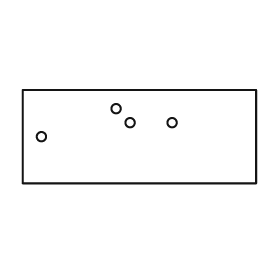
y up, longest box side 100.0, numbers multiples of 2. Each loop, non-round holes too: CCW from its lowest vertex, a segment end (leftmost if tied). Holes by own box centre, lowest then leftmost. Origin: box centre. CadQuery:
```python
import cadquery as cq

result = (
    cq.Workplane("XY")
    .moveTo(-50.0, -20.0)
    .lineTo(50.0, -20.0)
    .lineTo(50.0, 20.0)
    .lineTo(-50.0, 20.0)
    .close()
    .moveTo(-42.0, 0.0)
    .circle(2.0)
    .moveTo(-4.0, 6.0)
    .circle(2.0)
    .moveTo(14.0, 6.0)
    .circle(2.0)
    .moveTo(-10.0, 12.0)
    .circle(2.0)
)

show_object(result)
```